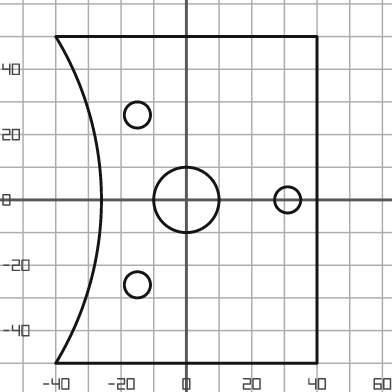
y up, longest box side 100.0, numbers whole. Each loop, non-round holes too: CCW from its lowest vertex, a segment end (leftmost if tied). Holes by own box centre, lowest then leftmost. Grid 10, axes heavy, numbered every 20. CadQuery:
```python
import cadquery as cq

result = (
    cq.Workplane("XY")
    .moveTo(-40.0, -50.0)
    .lineTo(40.0, -50.0)
    .lineTo(40.0, 50.0)
    .lineTo(-40.0, 50.0)
    .threePointArc((-26.0, 0.0), (-40.0, -50.0))
    .close()
    .moveTo(-15.0, -26.0)
    .circle(4.0)
    .moveTo(0.0, 0.0)
    .circle(10.0)
    .moveTo(31.0, 0.0)
    .circle(4.0)
    .moveTo(-15.0, 26.0)
    .circle(4.0)
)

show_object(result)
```